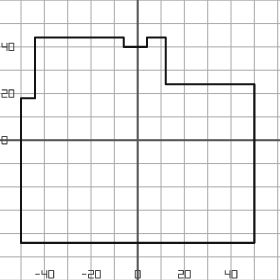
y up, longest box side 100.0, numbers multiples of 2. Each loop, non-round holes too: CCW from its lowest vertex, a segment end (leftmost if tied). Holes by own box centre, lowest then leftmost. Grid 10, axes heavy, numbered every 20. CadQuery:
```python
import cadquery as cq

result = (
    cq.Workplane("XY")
    .moveTo(-50.0, -44.0)
    .lineTo(50.0, -44.0)
    .lineTo(50.0, 24.0)
    .lineTo(12.0, 24.0)
    .lineTo(12.0, 44.0)
    .lineTo(4.0, 44.0)
    .lineTo(4.0, 40.0)
    .lineTo(-6.0, 40.0)
    .lineTo(-6.0, 44.0)
    .lineTo(-44.0, 44.0)
    .lineTo(-44.0, 18.0)
    .lineTo(-50.0, 18.0)
    .close()
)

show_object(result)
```